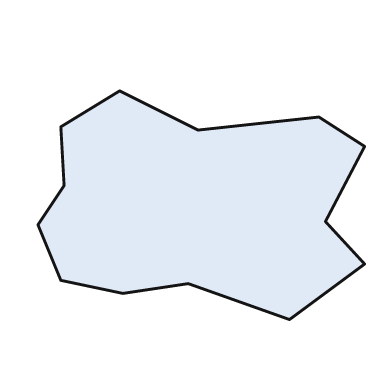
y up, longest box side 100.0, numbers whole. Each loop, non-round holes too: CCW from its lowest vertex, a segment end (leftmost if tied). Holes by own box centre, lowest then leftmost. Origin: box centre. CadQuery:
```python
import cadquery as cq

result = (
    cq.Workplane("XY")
    .moveTo(27.0, -35.0)
    .lineTo(50.0, -18.0)
    .lineTo(38.0, -5.0)
    .lineTo(50.0, 18.0)
    .lineTo(36.0, 27.0)
    .lineTo(-1.0, 23.0)
    .lineTo(-25.0, 35.0)
    .lineTo(-43.0, 24.0)
    .lineTo(-42.0, 6.0)
    .lineTo(-50.0, -6.0)
    .lineTo(-43.0, -23.0)
    .lineTo(-24.0, -27.0)
    .lineTo(-4.0, -24.0)
    .close()
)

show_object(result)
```